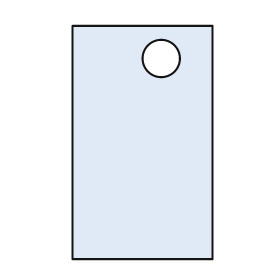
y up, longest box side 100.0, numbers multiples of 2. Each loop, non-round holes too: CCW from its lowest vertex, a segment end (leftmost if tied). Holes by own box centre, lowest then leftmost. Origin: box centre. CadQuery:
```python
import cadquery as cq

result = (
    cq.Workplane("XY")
    .moveTo(-30.0, -50.0)
    .lineTo(30.0, -50.0)
    .lineTo(30.0, 50.0)
    .lineTo(-30.0, 50.0)
    .close()
    .moveTo(8.0, 36.0)
    .circle(8.0)
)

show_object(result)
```